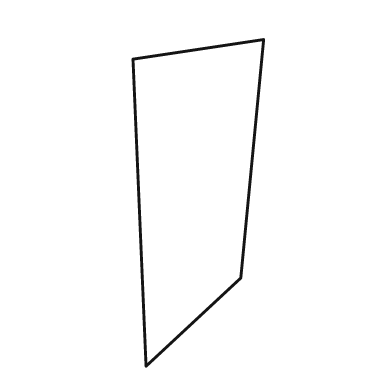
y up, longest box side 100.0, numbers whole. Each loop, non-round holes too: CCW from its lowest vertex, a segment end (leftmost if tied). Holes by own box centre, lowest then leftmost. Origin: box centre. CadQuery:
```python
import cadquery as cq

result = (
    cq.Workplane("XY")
    .moveTo(-16.0, -50.0)
    .lineTo(13.0, -23.0)
    .lineTo(20.0, 50.0)
    .lineTo(-20.0, 44.0)
    .close()
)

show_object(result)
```